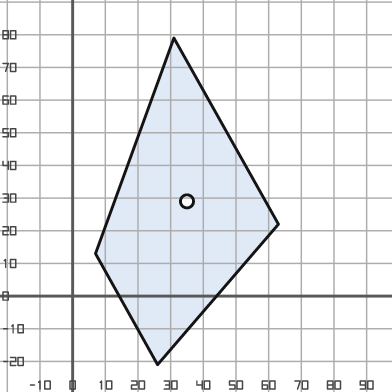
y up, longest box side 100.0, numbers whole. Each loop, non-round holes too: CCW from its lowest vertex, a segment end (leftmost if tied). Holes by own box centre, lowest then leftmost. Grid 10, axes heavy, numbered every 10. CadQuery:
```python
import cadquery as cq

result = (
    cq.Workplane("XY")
    .moveTo(26.0, -21.0)
    .lineTo(63.0, 22.0)
    .lineTo(31.0, 79.0)
    .lineTo(7.0, 13.0)
    .close()
    .moveTo(35.0, 29.0)
    .circle(2.0)
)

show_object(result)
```